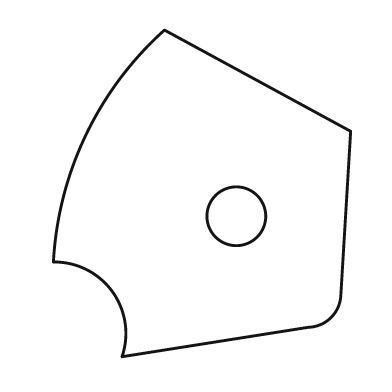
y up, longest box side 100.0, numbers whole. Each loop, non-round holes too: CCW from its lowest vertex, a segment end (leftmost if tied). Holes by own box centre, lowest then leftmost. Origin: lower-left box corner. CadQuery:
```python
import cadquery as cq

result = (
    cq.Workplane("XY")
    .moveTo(21.0, 0.0)
    .lineTo(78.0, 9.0)
    .threePointArc((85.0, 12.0), (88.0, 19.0))
    .lineTo(91.0, 69.0)
    .lineTo(34.0, 100.0)
    .threePointArc((10.0, 68.0), (0.0, 29.0))
    .threePointArc((18.0, 20.0), (21.0, 0.0))
    .close()
    .moveTo(56.0, 43.0)
    .circle(9.0)
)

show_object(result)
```